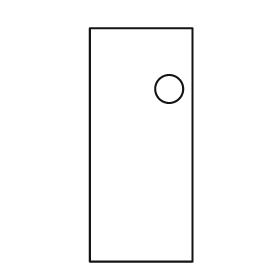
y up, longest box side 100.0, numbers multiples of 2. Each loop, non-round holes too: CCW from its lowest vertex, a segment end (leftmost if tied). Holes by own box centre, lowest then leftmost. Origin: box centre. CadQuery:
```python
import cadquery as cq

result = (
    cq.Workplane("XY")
    .moveTo(-22.0, -50.0)
    .lineTo(22.0, -50.0)
    .lineTo(22.0, 50.0)
    .lineTo(-22.0, 50.0)
    .close()
    .moveTo(12.0, 24.0)
    .circle(6.0)
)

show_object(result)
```